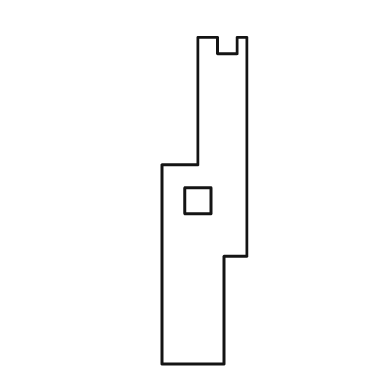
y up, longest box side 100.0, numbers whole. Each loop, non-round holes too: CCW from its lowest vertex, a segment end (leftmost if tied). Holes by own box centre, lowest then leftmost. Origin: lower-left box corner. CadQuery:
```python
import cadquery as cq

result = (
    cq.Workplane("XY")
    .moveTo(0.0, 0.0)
    .lineTo(19.0, 0.0)
    .lineTo(19.0, 33.0)
    .lineTo(26.0, 33.0)
    .lineTo(26.0, 100.0)
    .lineTo(23.0, 100.0)
    .lineTo(23.0, 95.0)
    .lineTo(17.0, 95.0)
    .lineTo(17.0, 100.0)
    .lineTo(11.0, 100.0)
    .lineTo(11.0, 61.0)
    .lineTo(0.0, 61.0)
    .close()
    .moveTo(7.0, 46.0)
    .lineTo(15.0, 46.0)
    .lineTo(15.0, 54.0)
    .lineTo(7.0, 54.0)
    .close()
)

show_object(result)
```